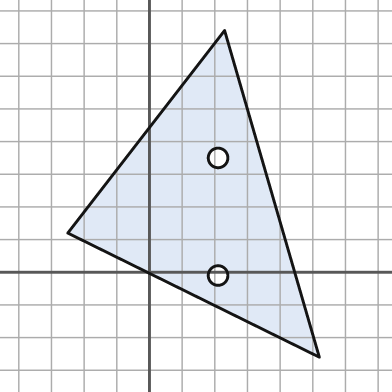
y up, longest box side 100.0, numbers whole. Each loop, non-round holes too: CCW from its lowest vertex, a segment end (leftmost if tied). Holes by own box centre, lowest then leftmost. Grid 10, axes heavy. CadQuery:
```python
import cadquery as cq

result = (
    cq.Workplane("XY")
    .moveTo(52.0, -26.0)
    .lineTo(23.0, 74.0)
    .lineTo(-25.0, 12.0)
    .close()
    .moveTo(21.0, -1.0)
    .circle(3.0)
    .moveTo(21.0, 35.0)
    .circle(3.0)
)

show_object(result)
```